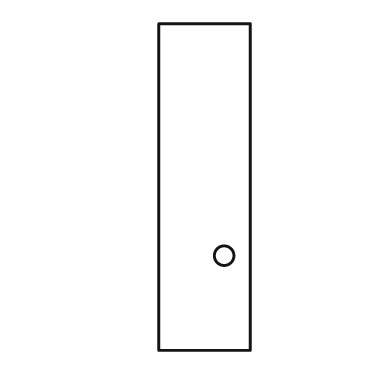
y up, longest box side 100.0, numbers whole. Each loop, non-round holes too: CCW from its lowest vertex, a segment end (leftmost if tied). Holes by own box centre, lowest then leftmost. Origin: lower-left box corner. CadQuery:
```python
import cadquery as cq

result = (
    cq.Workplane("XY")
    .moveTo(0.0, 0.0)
    .lineTo(28.0, 0.0)
    .lineTo(28.0, 100.0)
    .lineTo(0.0, 100.0)
    .close()
    .moveTo(20.0, 29.0)
    .circle(3.0)
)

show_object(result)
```